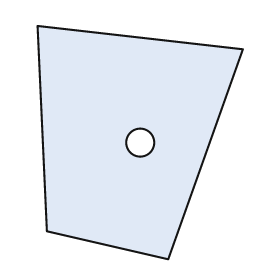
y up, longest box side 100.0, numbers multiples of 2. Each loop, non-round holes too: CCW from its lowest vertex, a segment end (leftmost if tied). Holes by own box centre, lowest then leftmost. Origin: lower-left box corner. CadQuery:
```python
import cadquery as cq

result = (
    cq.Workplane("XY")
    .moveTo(56.0, 0.0)
    .lineTo(88.0, 90.0)
    .lineTo(0.0, 100.0)
    .lineTo(4.0, 12.0)
    .close()
    .moveTo(44.0, 50.0)
    .circle(6.0)
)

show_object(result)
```